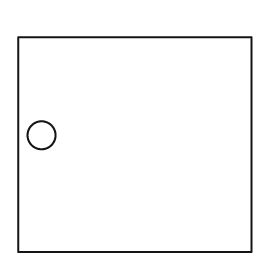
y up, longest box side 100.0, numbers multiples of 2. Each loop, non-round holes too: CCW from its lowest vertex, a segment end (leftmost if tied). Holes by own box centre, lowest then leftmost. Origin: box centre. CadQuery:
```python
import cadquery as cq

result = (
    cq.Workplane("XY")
    .moveTo(-50.0, -46.0)
    .lineTo(50.0, -46.0)
    .lineTo(50.0, 46.0)
    .lineTo(-50.0, 46.0)
    .close()
    .moveTo(-40.0, 4.0)
    .circle(6.0)
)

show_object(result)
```